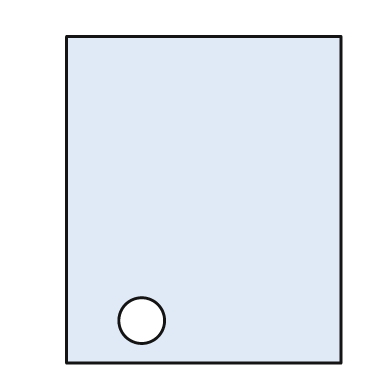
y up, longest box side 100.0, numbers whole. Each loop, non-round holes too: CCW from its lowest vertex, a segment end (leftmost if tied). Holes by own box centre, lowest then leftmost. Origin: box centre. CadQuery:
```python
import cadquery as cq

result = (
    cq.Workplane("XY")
    .moveTo(-42.0, -50.0)
    .lineTo(42.0, -50.0)
    .lineTo(42.0, 50.0)
    .lineTo(-42.0, 50.0)
    .close()
    .moveTo(-19.0, -37.0)
    .circle(7.0)
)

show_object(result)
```